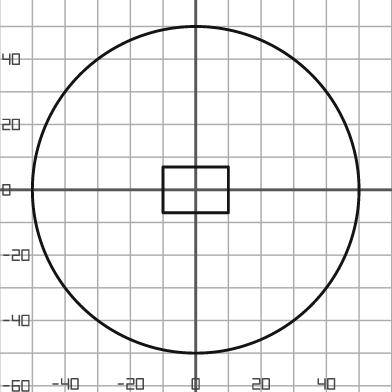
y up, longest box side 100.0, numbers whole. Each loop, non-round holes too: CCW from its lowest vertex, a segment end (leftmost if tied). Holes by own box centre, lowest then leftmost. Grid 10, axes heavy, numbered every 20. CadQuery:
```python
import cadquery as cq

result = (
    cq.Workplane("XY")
    .moveTo(0.0, 0.0)
    .circle(50.0)
    .moveTo(-10.0, -7.0)
    .lineTo(10.0, -7.0)
    .lineTo(10.0, 7.0)
    .lineTo(-10.0, 7.0)
    .close()
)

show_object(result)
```